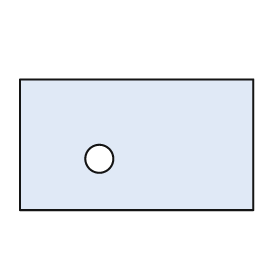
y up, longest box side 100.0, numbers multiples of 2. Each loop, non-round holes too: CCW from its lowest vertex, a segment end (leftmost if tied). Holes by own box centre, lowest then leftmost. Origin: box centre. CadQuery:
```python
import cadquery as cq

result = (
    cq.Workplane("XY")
    .moveTo(-50.0, -28.0)
    .lineTo(50.0, -28.0)
    .lineTo(50.0, 28.0)
    .lineTo(-50.0, 28.0)
    .close()
    .moveTo(-16.0, -6.0)
    .circle(6.0)
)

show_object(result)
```